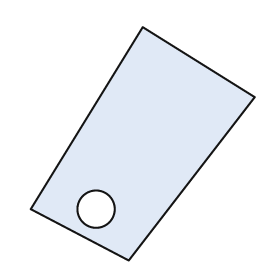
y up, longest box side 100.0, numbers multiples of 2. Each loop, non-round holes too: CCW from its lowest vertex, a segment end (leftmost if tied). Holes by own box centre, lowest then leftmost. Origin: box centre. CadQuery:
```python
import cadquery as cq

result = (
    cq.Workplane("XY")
    .moveTo(-6.0, -50.0)
    .lineTo(48.0, 20.0)
    .lineTo(0.0, 50.0)
    .lineTo(-48.0, -28.0)
    .close()
    .moveTo(-20.0, -28.0)
    .circle(8.0)
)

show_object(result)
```